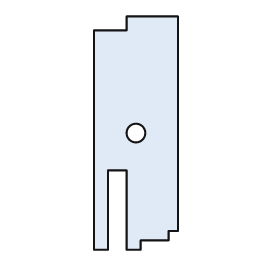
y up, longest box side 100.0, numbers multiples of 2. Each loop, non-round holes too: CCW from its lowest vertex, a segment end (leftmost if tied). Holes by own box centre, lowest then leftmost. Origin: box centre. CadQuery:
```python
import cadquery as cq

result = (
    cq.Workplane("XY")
    .moveTo(-18.0, -50.0)
    .lineTo(-12.0, -50.0)
    .lineTo(-12.0, -16.0)
    .lineTo(-4.0, -16.0)
    .lineTo(-4.0, -50.0)
    .lineTo(2.0, -50.0)
    .lineTo(2.0, -46.0)
    .lineTo(14.0, -46.0)
    .lineTo(14.0, -42.0)
    .lineTo(18.0, -42.0)
    .lineTo(18.0, 50.0)
    .lineTo(-4.0, 50.0)
    .lineTo(-4.0, 44.0)
    .lineTo(-18.0, 44.0)
    .close()
    .moveTo(0.0, 0.0)
    .circle(4.0)
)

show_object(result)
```